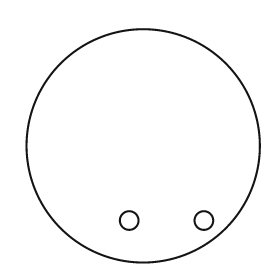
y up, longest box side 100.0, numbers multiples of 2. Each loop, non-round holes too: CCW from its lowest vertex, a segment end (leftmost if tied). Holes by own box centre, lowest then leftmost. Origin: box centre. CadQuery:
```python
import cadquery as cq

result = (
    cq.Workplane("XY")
    .moveTo(0.0, 0.0)
    .circle(50.0)
    .moveTo(-6.0, -32.0)
    .circle(4.0)
    .moveTo(26.0, -32.0)
    .circle(4.0)
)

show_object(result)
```